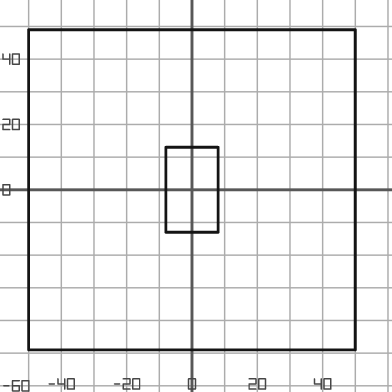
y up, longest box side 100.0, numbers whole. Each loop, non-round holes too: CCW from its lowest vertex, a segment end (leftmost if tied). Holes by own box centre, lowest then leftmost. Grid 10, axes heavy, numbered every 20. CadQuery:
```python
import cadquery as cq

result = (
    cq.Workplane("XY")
    .moveTo(-50.0, -49.0)
    .lineTo(50.0, -49.0)
    .lineTo(50.0, 49.0)
    .lineTo(-50.0, 49.0)
    .close()
    .moveTo(-8.0, -13.0)
    .lineTo(8.0, -13.0)
    .lineTo(8.0, 13.0)
    .lineTo(-8.0, 13.0)
    .close()
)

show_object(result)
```